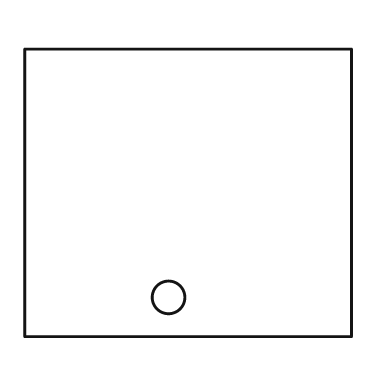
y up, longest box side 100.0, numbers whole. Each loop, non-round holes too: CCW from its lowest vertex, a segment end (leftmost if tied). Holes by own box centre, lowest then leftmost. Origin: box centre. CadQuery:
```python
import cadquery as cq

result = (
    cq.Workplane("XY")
    .moveTo(-50.0, -44.0)
    .lineTo(50.0, -44.0)
    .lineTo(50.0, 44.0)
    .lineTo(-50.0, 44.0)
    .close()
    .moveTo(-6.0, -32.0)
    .circle(5.0)
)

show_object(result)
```